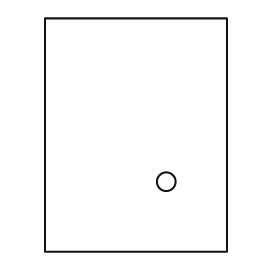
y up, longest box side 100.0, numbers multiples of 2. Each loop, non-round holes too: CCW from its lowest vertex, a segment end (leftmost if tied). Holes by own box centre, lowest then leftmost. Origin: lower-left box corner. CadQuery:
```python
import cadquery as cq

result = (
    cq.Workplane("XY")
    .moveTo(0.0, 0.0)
    .lineTo(78.0, 0.0)
    .lineTo(78.0, 100.0)
    .lineTo(0.0, 100.0)
    .close()
    .moveTo(52.0, 30.0)
    .circle(4.0)
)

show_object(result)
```